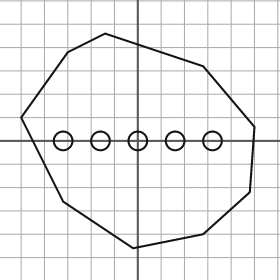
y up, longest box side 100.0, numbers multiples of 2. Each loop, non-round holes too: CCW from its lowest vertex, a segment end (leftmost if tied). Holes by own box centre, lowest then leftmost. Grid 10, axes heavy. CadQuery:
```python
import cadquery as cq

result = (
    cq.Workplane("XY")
    .moveTo(-2.0, -46.0)
    .lineTo(28.0, -40.0)
    .lineTo(48.0, -22.0)
    .lineTo(50.0, 6.0)
    .lineTo(28.0, 32.0)
    .lineTo(-14.0, 46.0)
    .lineTo(-30.0, 38.0)
    .lineTo(-50.0, 10.0)
    .lineTo(-32.0, -26.0)
    .close()
    .moveTo(-32.0, 0.0)
    .circle(4.0)
    .moveTo(-16.0, 0.0)
    .circle(4.0)
    .moveTo(0.0, 0.0)
    .circle(4.0)
    .moveTo(16.0, 0.0)
    .circle(4.0)
    .moveTo(32.0, 0.0)
    .circle(4.0)
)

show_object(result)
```